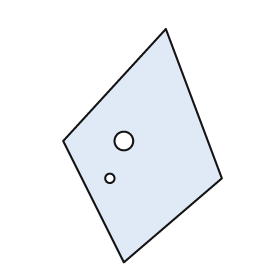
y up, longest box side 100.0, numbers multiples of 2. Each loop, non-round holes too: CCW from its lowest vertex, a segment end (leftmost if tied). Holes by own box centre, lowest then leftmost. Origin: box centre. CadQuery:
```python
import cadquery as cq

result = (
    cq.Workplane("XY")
    .moveTo(-8.0, -50.0)
    .lineTo(34.0, -14.0)
    .lineTo(10.0, 50.0)
    .lineTo(-34.0, 2.0)
    .close()
    .moveTo(-14.0, -14.0)
    .circle(2.0)
    .moveTo(-8.0, 2.0)
    .circle(4.0)
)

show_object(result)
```